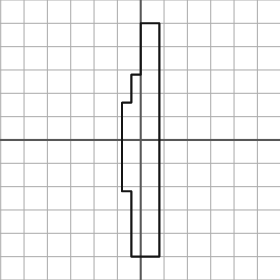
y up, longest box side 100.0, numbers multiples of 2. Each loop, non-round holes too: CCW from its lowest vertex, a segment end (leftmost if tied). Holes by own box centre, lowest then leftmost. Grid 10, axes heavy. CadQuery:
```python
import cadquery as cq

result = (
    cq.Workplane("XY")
    .moveTo(-4.0, -50.0)
    .lineTo(8.0, -50.0)
    .lineTo(8.0, 50.0)
    .lineTo(0.0, 50.0)
    .lineTo(0.0, 28.0)
    .lineTo(-4.0, 28.0)
    .lineTo(-4.0, 16.0)
    .lineTo(-8.0, 16.0)
    .lineTo(-8.0, -22.0)
    .lineTo(-4.0, -22.0)
    .close()
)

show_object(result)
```